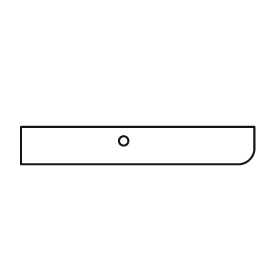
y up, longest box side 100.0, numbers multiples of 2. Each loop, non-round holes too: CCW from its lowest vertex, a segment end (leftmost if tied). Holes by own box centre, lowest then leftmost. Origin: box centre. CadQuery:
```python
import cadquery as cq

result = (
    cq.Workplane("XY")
    .moveTo(-50.0, -8.0)
    .lineTo(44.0, -8.0)
    .threePointArc((48.0, -6.0), (50.0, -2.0))
    .lineTo(50.0, 8.0)
    .lineTo(-50.0, 8.0)
    .close()
    .moveTo(-6.0, 2.0)
    .circle(2.0)
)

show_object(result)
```